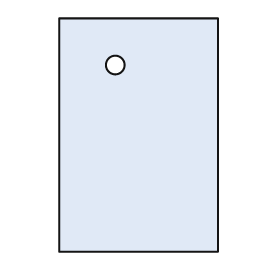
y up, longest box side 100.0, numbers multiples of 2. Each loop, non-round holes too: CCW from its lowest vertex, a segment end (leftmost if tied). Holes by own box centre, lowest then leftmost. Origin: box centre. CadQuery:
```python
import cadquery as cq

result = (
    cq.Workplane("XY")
    .moveTo(-34.0, -50.0)
    .lineTo(34.0, -50.0)
    .lineTo(34.0, 50.0)
    .lineTo(-34.0, 50.0)
    .close()
    .moveTo(-10.0, 30.0)
    .circle(4.0)
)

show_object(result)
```